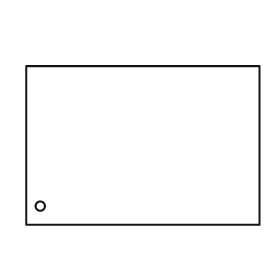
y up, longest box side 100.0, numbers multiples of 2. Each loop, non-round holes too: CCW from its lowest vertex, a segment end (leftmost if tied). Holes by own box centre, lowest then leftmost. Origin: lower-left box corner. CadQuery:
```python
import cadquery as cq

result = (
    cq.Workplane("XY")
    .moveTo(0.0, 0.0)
    .lineTo(100.0, 0.0)
    .lineTo(100.0, 68.0)
    .lineTo(0.0, 68.0)
    .close()
    .moveTo(6.0, 8.0)
    .circle(2.0)
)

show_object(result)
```